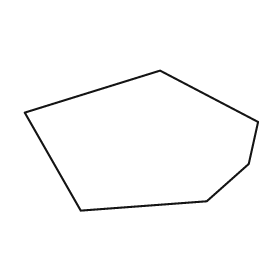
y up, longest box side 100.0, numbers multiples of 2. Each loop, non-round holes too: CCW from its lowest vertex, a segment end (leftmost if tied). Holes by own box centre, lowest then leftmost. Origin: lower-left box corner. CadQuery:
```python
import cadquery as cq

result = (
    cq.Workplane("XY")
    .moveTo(24.0, 0.0)
    .lineTo(78.0, 4.0)
    .lineTo(96.0, 20.0)
    .lineTo(100.0, 38.0)
    .lineTo(58.0, 60.0)
    .lineTo(0.0, 42.0)
    .close()
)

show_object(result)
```